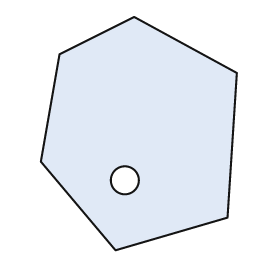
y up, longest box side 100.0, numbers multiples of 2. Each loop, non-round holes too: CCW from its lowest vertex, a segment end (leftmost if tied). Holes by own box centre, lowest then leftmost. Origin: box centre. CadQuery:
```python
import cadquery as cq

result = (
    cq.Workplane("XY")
    .moveTo(-10.0, -50.0)
    .lineTo(38.0, -36.0)
    .lineTo(42.0, 26.0)
    .lineTo(-2.0, 50.0)
    .lineTo(-34.0, 34.0)
    .lineTo(-42.0, -12.0)
    .close()
    .moveTo(-6.0, -20.0)
    .circle(6.0)
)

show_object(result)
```